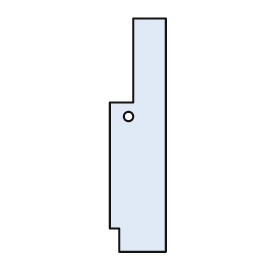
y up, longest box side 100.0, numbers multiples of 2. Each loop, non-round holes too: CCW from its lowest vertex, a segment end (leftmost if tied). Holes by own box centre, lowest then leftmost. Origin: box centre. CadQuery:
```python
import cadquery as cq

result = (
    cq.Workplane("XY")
    .moveTo(-8.0, -50.0)
    .lineTo(12.0, -50.0)
    .lineTo(12.0, 50.0)
    .lineTo(-2.0, 50.0)
    .lineTo(-2.0, 14.0)
    .lineTo(-12.0, 14.0)
    .lineTo(-12.0, -40.0)
    .lineTo(-8.0, -40.0)
    .close()
    .moveTo(-4.0, 8.0)
    .circle(2.0)
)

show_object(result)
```